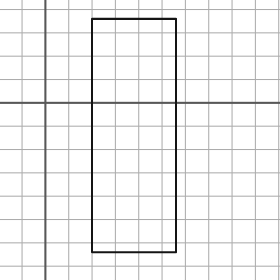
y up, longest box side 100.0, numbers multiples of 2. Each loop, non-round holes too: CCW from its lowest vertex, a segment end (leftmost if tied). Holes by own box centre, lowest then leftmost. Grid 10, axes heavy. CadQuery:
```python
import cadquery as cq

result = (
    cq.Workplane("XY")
    .moveTo(20.0, -64.0)
    .lineTo(56.0, -64.0)
    .lineTo(56.0, 36.0)
    .lineTo(20.0, 36.0)
    .close()
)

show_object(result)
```